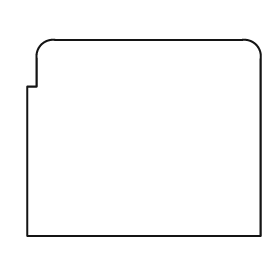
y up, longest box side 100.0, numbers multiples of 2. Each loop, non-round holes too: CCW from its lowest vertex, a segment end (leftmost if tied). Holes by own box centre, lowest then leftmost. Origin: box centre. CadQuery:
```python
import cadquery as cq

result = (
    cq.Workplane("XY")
    .moveTo(-50.0, -42.0)
    .lineTo(50.0, -42.0)
    .lineTo(50.0, 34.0)
    .threePointArc((48.0, 40.0), (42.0, 42.0))
    .lineTo(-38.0, 42.0)
    .threePointArc((-44.0, 40.0), (-46.0, 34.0))
    .lineTo(-46.0, 22.0)
    .lineTo(-50.0, 22.0)
    .close()
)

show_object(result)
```